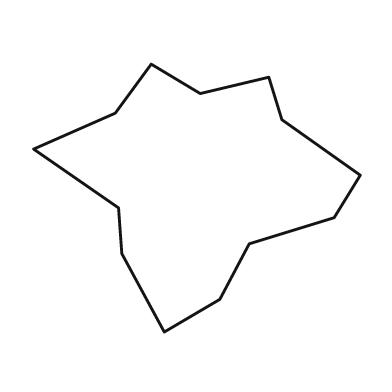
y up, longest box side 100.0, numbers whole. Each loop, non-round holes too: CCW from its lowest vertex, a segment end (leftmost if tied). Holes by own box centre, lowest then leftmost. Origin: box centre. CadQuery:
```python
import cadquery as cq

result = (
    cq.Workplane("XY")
    .moveTo(-10.0, -41.0)
    .lineTo(7.0, -31.0)
    .lineTo(16.0, -14.0)
    .lineTo(42.0, -6.0)
    .lineTo(50.0, 7.0)
    .lineTo(26.0, 24.0)
    .lineTo(22.0, 37.0)
    .lineTo(1.0, 32.0)
    .lineTo(-14.0, 41.0)
    .lineTo(-25.0, 26.0)
    .lineTo(-50.0, 15.0)
    .lineTo(-24.0, -3.0)
    .lineTo(-23.0, -17.0)
    .close()
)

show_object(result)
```